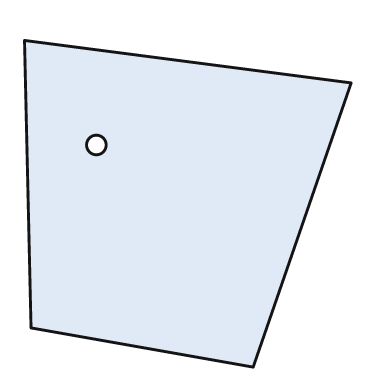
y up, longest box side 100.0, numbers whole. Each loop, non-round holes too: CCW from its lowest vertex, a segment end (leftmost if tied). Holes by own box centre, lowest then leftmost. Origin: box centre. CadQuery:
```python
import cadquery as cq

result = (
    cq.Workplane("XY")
    .moveTo(20.0, -50.0)
    .lineTo(50.0, 37.0)
    .lineTo(-50.0, 50.0)
    .lineTo(-48.0, -38.0)
    .close()
    .moveTo(-28.0, 18.0)
    .circle(3.0)
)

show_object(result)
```